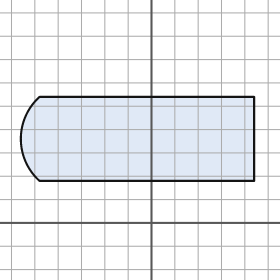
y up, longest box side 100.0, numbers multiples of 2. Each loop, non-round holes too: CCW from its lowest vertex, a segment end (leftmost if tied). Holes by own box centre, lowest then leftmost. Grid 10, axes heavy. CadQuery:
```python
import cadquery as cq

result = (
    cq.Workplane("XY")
    .moveTo(-48.0, 18.0)
    .lineTo(44.0, 18.0)
    .lineTo(44.0, 54.0)
    .lineTo(-48.0, 54.0)
    .threePointArc((-56.0, 36.0), (-48.0, 18.0))
    .close()
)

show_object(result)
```